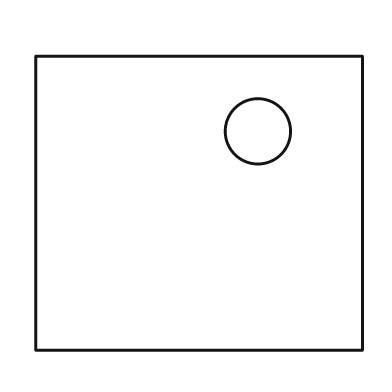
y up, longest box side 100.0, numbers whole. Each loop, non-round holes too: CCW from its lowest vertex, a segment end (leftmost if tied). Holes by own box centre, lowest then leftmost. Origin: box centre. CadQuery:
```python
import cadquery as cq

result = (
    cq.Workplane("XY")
    .moveTo(-50.0, -45.0)
    .lineTo(50.0, -45.0)
    .lineTo(50.0, 45.0)
    .lineTo(-50.0, 45.0)
    .close()
    .moveTo(18.0, 22.0)
    .circle(10.0)
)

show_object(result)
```